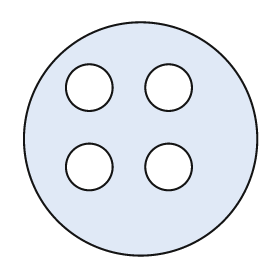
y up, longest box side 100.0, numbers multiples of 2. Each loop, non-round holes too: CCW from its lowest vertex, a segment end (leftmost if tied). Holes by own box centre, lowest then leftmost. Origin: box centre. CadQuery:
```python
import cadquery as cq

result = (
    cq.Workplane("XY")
    .moveTo(0.0, 0.0)
    .circle(50.0)
    .moveTo(-22.0, -12.0)
    .circle(10.0)
    .moveTo(12.0, -12.0)
    .circle(10.0)
    .moveTo(-22.0, 22.0)
    .circle(10.0)
    .moveTo(12.0, 22.0)
    .circle(10.0)
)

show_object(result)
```